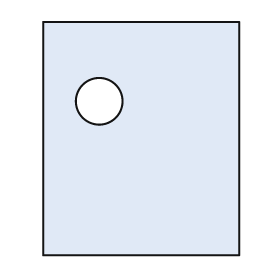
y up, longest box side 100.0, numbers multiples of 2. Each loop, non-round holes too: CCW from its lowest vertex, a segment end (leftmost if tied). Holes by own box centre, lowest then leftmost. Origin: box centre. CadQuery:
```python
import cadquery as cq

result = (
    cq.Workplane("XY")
    .moveTo(-42.0, -50.0)
    .lineTo(42.0, -50.0)
    .lineTo(42.0, 50.0)
    .lineTo(-42.0, 50.0)
    .close()
    .moveTo(-18.0, 16.0)
    .circle(10.0)
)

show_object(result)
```